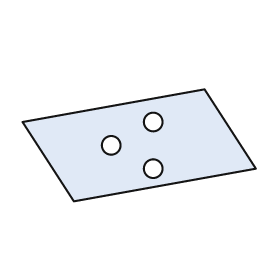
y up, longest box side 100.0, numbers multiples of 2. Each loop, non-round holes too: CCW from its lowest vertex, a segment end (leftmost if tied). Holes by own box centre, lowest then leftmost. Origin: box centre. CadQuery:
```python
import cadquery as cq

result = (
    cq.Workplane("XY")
    .moveTo(-28.0, -24.0)
    .lineTo(50.0, -10.0)
    .lineTo(28.0, 24.0)
    .lineTo(-50.0, 10.0)
    .close()
    .moveTo(6.0, -10.0)
    .circle(4.0)
    .moveTo(-12.0, 0.0)
    .circle(4.0)
    .moveTo(6.0, 10.0)
    .circle(4.0)
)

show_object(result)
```